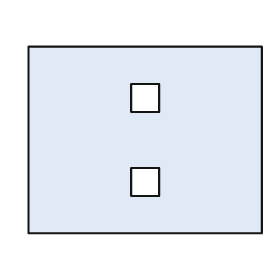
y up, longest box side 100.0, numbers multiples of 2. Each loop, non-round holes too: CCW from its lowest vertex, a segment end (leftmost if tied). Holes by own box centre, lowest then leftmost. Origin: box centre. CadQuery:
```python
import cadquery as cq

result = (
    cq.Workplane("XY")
    .moveTo(-50.0, -40.0)
    .lineTo(50.0, -40.0)
    .lineTo(50.0, 40.0)
    .lineTo(-50.0, 40.0)
    .close()
    .moveTo(-6.0, -24.0)
    .lineTo(6.0, -24.0)
    .lineTo(6.0, -12.0)
    .lineTo(-6.0, -12.0)
    .close()
    .moveTo(-6.0, 12.0)
    .lineTo(6.0, 12.0)
    .lineTo(6.0, 24.0)
    .lineTo(-6.0, 24.0)
    .close()
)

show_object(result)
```